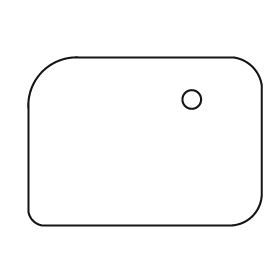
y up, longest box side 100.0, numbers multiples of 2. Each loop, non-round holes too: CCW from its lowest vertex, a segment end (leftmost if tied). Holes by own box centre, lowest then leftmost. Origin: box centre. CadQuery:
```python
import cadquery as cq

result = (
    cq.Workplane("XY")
    .moveTo(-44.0, -36.0)
    .lineTo(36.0, -36.0)
    .threePointArc((46.0, -32.0), (50.0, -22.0))
    .lineTo(50.0, 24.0)
    .threePointArc((46.0, 32.0), (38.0, 36.0))
    .lineTo(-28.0, 36.0)
    .threePointArc((-44.0, 30.0), (-50.0, 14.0))
    .lineTo(-50.0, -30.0)
    .threePointArc((-48.0, -34.0), (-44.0, -36.0))
    .close()
    .moveTo(20.0, 18.0)
    .circle(4.0)
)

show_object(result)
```